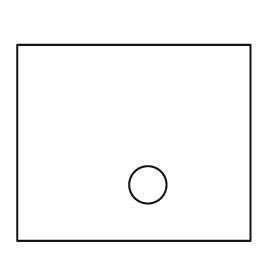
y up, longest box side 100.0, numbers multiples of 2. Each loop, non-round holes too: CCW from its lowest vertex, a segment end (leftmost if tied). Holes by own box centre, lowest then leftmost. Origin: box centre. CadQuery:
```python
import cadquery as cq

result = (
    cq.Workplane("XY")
    .moveTo(-50.0, -42.0)
    .lineTo(50.0, -42.0)
    .lineTo(50.0, 42.0)
    .lineTo(-50.0, 42.0)
    .close()
    .moveTo(6.0, -18.0)
    .circle(8.0)
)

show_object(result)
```